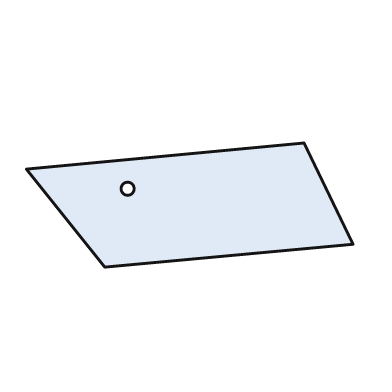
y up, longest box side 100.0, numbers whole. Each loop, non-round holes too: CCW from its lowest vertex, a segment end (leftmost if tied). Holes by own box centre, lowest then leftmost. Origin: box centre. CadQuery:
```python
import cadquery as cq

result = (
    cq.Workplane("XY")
    .moveTo(-26.0, -19.0)
    .lineTo(50.0, -12.0)
    .lineTo(35.0, 19.0)
    .lineTo(-50.0, 11.0)
    .close()
    .moveTo(-19.0, 5.0)
    .circle(2.0)
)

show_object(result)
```